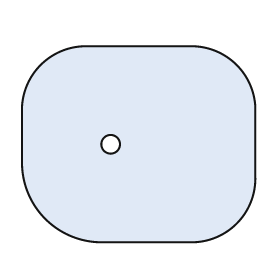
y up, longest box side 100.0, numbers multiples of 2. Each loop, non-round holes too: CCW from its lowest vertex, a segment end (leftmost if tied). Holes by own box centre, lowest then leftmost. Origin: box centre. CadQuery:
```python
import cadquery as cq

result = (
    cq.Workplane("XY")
    .moveTo(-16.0, -42.0)
    .lineTo(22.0, -42.0)
    .threePointArc((42.0, -34.0), (50.0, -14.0))
    .lineTo(50.0, 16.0)
    .threePointArc((42.0, 34.0), (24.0, 42.0))
    .lineTo(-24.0, 42.0)
    .threePointArc((-42.0, 34.0), (-50.0, 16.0))
    .lineTo(-50.0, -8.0)
    .threePointArc((-40.0, -32.0), (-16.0, -42.0))
    .close()
    .moveTo(-12.0, 0.0)
    .circle(4.0)
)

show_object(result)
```